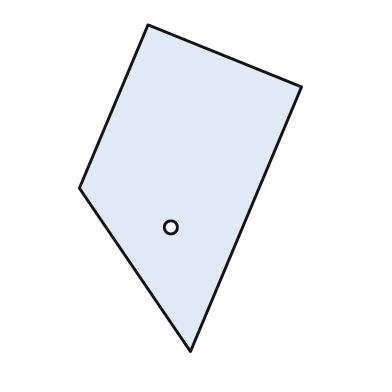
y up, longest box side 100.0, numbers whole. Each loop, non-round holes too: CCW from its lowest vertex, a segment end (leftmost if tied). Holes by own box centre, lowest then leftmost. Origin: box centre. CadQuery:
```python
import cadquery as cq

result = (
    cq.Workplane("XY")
    .moveTo(0.0, -50.0)
    .lineTo(34.0, 31.0)
    .lineTo(-13.0, 50.0)
    .lineTo(-34.0, 0.0)
    .close()
    .moveTo(-6.0, -12.0)
    .circle(2.0)
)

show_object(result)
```